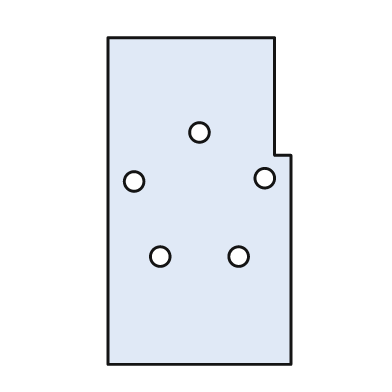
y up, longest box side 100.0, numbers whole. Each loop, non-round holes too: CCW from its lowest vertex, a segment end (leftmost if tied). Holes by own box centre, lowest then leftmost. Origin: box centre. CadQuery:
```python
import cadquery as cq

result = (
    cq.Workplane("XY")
    .moveTo(-28.0, -50.0)
    .lineTo(28.0, -50.0)
    .lineTo(28.0, 14.0)
    .lineTo(23.0, 14.0)
    .lineTo(23.0, 50.0)
    .lineTo(-28.0, 50.0)
    .close()
    .moveTo(-12.0, -17.0)
    .circle(3.0)
    .moveTo(12.0, -17.0)
    .circle(3.0)
    .moveTo(-20.0, 6.0)
    .circle(3.0)
    .moveTo(20.0, 7.0)
    .circle(3.0)
    .moveTo(0.0, 21.0)
    .circle(3.0)
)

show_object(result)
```